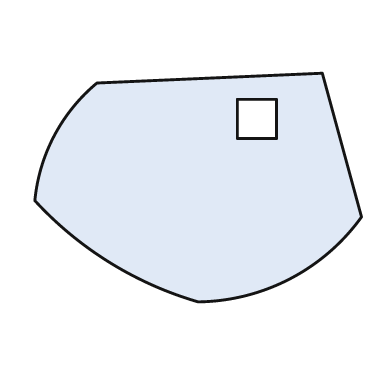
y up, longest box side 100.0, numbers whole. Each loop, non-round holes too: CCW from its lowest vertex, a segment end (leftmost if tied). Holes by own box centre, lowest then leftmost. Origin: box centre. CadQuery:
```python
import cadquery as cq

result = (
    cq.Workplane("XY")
    .moveTo(0.0, -35.0)
    .threePointArc((28.0, -28.0), (50.0, -9.0))
    .lineTo(38.0, 35.0)
    .lineTo(-31.0, 32.0)
    .threePointArc((-44.0, 16.0), (-50.0, -4.0))
    .threePointArc((-27.0, -23.0), (0.0, -35.0))
    .close()
    .moveTo(12.0, 15.0)
    .lineTo(24.0, 15.0)
    .lineTo(24.0, 27.0)
    .lineTo(12.0, 27.0)
    .close()
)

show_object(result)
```